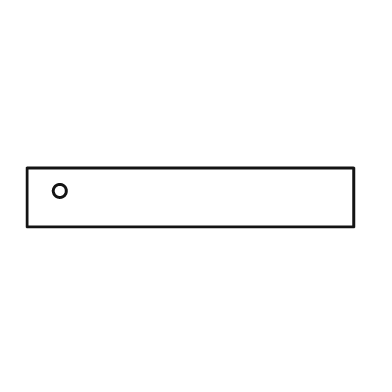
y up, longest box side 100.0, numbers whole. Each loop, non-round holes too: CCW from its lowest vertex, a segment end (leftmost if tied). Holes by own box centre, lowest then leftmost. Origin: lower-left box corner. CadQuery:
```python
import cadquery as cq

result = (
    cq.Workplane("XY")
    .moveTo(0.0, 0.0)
    .lineTo(100.0, 0.0)
    .lineTo(100.0, 18.0)
    .lineTo(0.0, 18.0)
    .close()
    .moveTo(10.0, 11.0)
    .circle(2.0)
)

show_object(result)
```